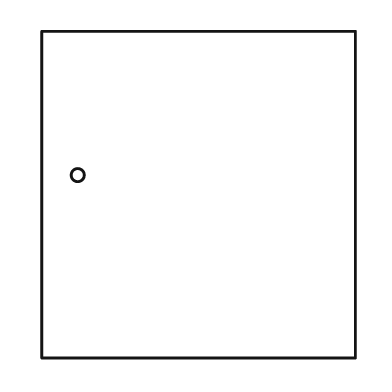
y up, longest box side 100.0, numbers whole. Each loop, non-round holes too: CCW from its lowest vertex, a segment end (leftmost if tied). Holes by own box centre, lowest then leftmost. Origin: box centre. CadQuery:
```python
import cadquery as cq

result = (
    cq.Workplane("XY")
    .moveTo(-48.0, -50.0)
    .lineTo(48.0, -50.0)
    .lineTo(48.0, 50.0)
    .lineTo(-48.0, 50.0)
    .close()
    .moveTo(-37.0, 6.0)
    .circle(2.0)
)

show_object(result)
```